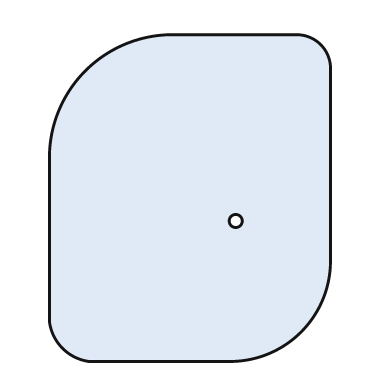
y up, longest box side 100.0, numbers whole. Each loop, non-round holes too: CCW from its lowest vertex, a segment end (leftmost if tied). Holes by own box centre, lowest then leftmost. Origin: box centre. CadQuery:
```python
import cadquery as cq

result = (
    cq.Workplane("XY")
    .moveTo(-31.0, -50.0)
    .lineTo(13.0, -50.0)
    .threePointArc((34.0, -41.0), (43.0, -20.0))
    .lineTo(43.0, 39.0)
    .threePointArc((40.0, 47.0), (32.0, 50.0))
    .lineTo(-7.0, 50.0)
    .threePointArc((-32.0, 39.0), (-43.0, 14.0))
    .lineTo(-43.0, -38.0)
    .threePointArc((-39.0, -46.0), (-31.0, -50.0))
    .close()
    .moveTo(14.0, -7.0)
    .circle(2.0)
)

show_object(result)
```